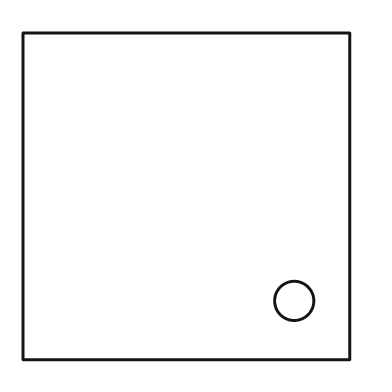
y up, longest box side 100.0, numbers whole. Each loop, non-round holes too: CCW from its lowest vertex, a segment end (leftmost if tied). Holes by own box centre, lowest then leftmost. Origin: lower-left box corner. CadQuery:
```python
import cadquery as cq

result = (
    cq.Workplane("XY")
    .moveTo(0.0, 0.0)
    .lineTo(100.0, 0.0)
    .lineTo(100.0, 100.0)
    .lineTo(0.0, 100.0)
    .close()
    .moveTo(83.0, 18.0)
    .circle(6.0)
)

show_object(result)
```